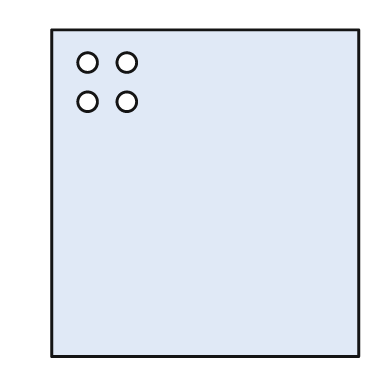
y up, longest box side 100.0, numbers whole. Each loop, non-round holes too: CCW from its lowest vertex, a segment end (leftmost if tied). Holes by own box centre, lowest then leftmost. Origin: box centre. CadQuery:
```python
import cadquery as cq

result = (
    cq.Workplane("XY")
    .moveTo(-47.0, -50.0)
    .lineTo(47.0, -50.0)
    .lineTo(47.0, 50.0)
    .lineTo(-47.0, 50.0)
    .close()
    .moveTo(-36.0, 28.0)
    .circle(3.0)
    .moveTo(-24.0, 28.0)
    .circle(3.0)
    .moveTo(-36.0, 40.0)
    .circle(3.0)
    .moveTo(-24.0, 40.0)
    .circle(3.0)
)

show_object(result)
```